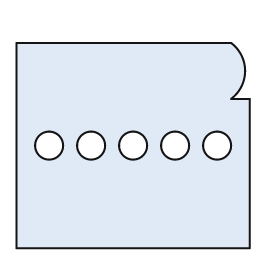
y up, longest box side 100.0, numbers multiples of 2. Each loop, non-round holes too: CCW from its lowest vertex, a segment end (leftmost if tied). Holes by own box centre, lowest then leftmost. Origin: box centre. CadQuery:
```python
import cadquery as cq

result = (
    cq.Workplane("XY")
    .moveTo(-50.0, -44.0)
    .lineTo(50.0, -44.0)
    .lineTo(50.0, 20.0)
    .lineTo(42.0, 20.0)
    .threePointArc((48.0, 32.0), (42.0, 44.0))
    .lineTo(-50.0, 44.0)
    .close()
    .moveTo(-36.0, 0.0)
    .circle(6.0)
    .moveTo(-18.0, 0.0)
    .circle(6.0)
    .moveTo(0.0, 0.0)
    .circle(6.0)
    .moveTo(18.0, 0.0)
    .circle(6.0)
    .moveTo(36.0, 0.0)
    .circle(6.0)
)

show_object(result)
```